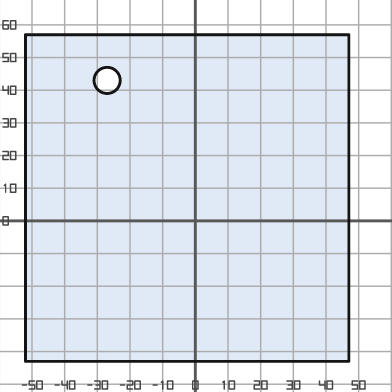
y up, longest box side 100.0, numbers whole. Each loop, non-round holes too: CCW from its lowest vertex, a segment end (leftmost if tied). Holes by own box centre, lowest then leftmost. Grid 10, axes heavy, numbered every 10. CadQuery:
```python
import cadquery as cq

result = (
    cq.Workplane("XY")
    .moveTo(-52.0, -43.0)
    .lineTo(47.0, -43.0)
    .lineTo(47.0, 57.0)
    .lineTo(-52.0, 57.0)
    .close()
    .moveTo(-27.0, 43.0)
    .circle(4.0)
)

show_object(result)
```